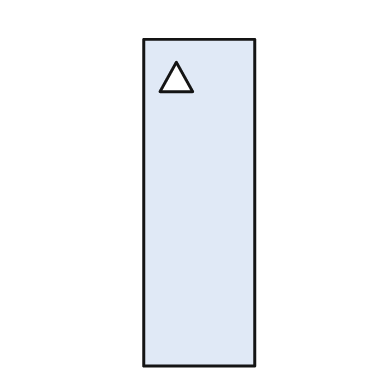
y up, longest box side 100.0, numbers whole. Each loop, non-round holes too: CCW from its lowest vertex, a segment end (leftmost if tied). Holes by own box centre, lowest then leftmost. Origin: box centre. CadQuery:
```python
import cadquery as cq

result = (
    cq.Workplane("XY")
    .moveTo(-17.0, -50.0)
    .lineTo(17.0, -50.0)
    .lineTo(17.0, 50.0)
    .lineTo(-17.0, 50.0)
    .close()
    .moveTo(-12.0, 34.0)
    .lineTo(-2.0, 34.0)
    .lineTo(-7.0, 43.0)
    .close()
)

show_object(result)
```